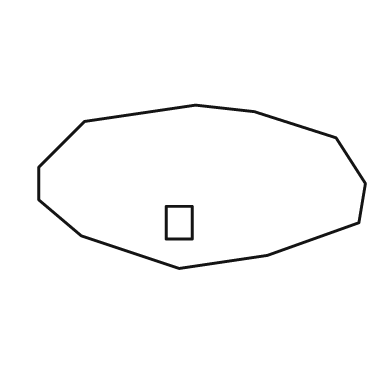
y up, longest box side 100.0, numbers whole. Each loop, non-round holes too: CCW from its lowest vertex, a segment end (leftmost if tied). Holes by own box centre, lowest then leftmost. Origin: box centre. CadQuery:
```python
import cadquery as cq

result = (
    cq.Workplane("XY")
    .moveTo(-7.0, -25.0)
    .lineTo(20.0, -21.0)
    .lineTo(48.0, -11.0)
    .lineTo(50.0, 1.0)
    .lineTo(41.0, 15.0)
    .lineTo(16.0, 23.0)
    .lineTo(-2.0, 25.0)
    .lineTo(-36.0, 20.0)
    .lineTo(-50.0, 6.0)
    .lineTo(-50.0, -4.0)
    .lineTo(-37.0, -15.0)
    .close()
    .moveTo(-11.0, -16.0)
    .lineTo(-3.0, -16.0)
    .lineTo(-3.0, -6.0)
    .lineTo(-11.0, -6.0)
    .close()
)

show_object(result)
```